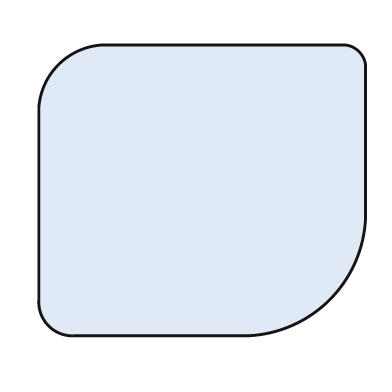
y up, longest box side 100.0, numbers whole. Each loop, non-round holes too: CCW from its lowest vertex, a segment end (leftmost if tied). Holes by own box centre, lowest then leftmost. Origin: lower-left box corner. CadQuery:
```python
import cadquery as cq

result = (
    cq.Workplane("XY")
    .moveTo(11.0, 0.0)
    .lineTo(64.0, 0.0)
    .threePointArc((89.0, 11.0), (100.0, 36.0))
    .lineTo(100.0, 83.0)
    .threePointArc((98.0, 87.0), (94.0, 89.0))
    .lineTo(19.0, 89.0)
    .threePointArc((6.0, 83.0), (0.0, 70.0))
    .lineTo(0.0, 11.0)
    .threePointArc((3.0, 3.0), (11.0, 0.0))
    .close()
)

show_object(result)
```